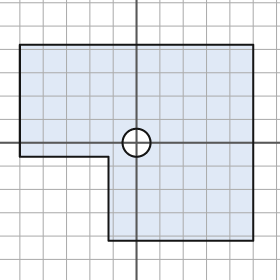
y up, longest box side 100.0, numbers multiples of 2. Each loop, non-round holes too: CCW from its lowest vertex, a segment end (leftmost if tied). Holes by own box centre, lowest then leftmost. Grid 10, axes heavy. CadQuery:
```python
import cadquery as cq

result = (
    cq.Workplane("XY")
    .moveTo(-12.0, -42.0)
    .lineTo(50.0, -42.0)
    .lineTo(50.0, 42.0)
    .lineTo(-50.0, 42.0)
    .lineTo(-50.0, -6.0)
    .lineTo(-12.0, -6.0)
    .close()
    .moveTo(0.0, 0.0)
    .circle(6.0)
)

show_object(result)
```